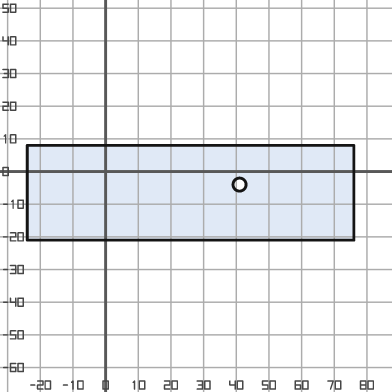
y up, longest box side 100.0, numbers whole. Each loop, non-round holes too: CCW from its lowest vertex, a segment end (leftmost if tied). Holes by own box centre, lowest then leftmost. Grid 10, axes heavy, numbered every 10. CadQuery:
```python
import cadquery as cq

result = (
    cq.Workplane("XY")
    .moveTo(-24.0, -21.0)
    .lineTo(76.0, -21.0)
    .lineTo(76.0, 8.0)
    .lineTo(-24.0, 8.0)
    .close()
    .moveTo(41.0, -4.0)
    .circle(2.0)
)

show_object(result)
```